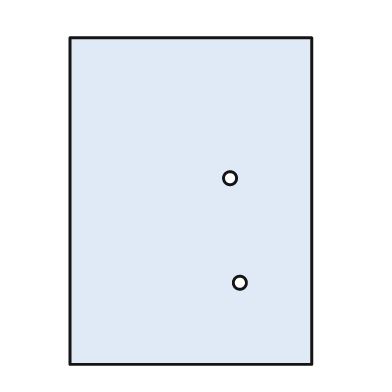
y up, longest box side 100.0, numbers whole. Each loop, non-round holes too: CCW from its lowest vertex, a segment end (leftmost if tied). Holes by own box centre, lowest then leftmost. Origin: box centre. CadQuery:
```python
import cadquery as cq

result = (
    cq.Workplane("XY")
    .moveTo(-37.0, -50.0)
    .lineTo(37.0, -50.0)
    .lineTo(37.0, 50.0)
    .lineTo(-37.0, 50.0)
    .close()
    .moveTo(15.0, -25.0)
    .circle(2.0)
    .moveTo(12.0, 7.0)
    .circle(2.0)
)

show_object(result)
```